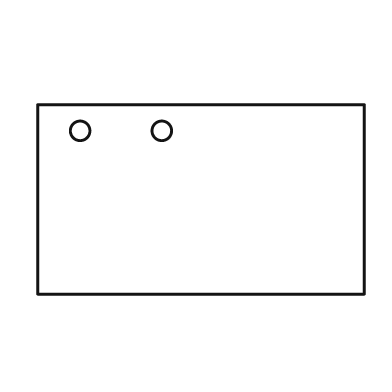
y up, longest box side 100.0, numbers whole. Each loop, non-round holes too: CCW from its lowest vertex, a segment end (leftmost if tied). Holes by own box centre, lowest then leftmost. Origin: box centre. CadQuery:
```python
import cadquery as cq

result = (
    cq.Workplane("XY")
    .moveTo(-50.0, -29.0)
    .lineTo(50.0, -29.0)
    .lineTo(50.0, 29.0)
    .lineTo(-50.0, 29.0)
    .close()
    .moveTo(-37.0, 21.0)
    .circle(3.0)
    .moveTo(-12.0, 21.0)
    .circle(3.0)
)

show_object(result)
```